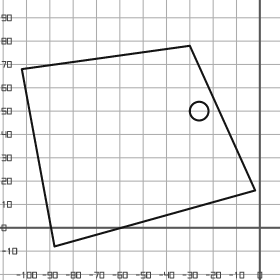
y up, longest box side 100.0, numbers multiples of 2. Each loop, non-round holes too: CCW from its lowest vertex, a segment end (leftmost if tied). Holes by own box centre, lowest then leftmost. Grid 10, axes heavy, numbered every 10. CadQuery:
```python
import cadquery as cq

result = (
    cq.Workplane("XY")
    .moveTo(-88.0, -8.0)
    .lineTo(-2.0, 16.0)
    .lineTo(-30.0, 78.0)
    .lineTo(-102.0, 68.0)
    .close()
    .moveTo(-26.0, 50.0)
    .circle(4.0)
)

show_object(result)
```